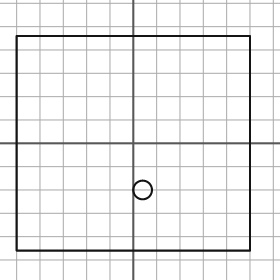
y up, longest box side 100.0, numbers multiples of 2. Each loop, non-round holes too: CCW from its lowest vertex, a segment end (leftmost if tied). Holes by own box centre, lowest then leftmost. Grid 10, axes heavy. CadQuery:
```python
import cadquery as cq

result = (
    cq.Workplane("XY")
    .moveTo(-50.0, -46.0)
    .lineTo(50.0, -46.0)
    .lineTo(50.0, 46.0)
    .lineTo(-50.0, 46.0)
    .close()
    .moveTo(4.0, -20.0)
    .circle(4.0)
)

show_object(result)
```